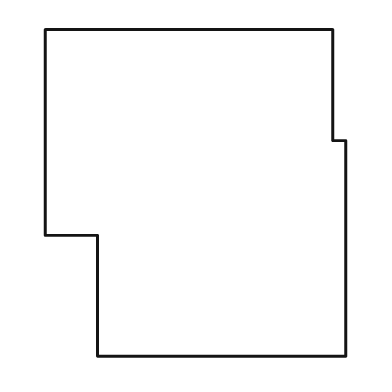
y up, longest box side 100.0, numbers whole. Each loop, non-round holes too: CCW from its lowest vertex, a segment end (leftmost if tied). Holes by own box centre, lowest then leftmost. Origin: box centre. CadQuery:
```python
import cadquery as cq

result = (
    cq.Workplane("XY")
    .moveTo(-30.0, -50.0)
    .lineTo(46.0, -50.0)
    .lineTo(46.0, 16.0)
    .lineTo(42.0, 16.0)
    .lineTo(42.0, 50.0)
    .lineTo(-46.0, 50.0)
    .lineTo(-46.0, -13.0)
    .lineTo(-30.0, -13.0)
    .close()
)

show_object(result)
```